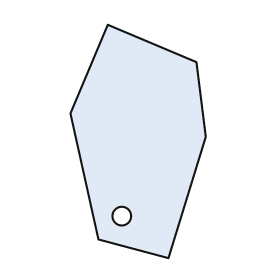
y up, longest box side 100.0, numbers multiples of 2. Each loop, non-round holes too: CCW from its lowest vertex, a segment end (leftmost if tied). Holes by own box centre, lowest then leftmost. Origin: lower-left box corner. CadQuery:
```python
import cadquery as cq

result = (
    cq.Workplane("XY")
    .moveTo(42.0, 0.0)
    .lineTo(58.0, 52.0)
    .lineTo(54.0, 84.0)
    .lineTo(16.0, 100.0)
    .lineTo(0.0, 62.0)
    .lineTo(12.0, 8.0)
    .close()
    .moveTo(22.0, 18.0)
    .circle(4.0)
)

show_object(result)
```